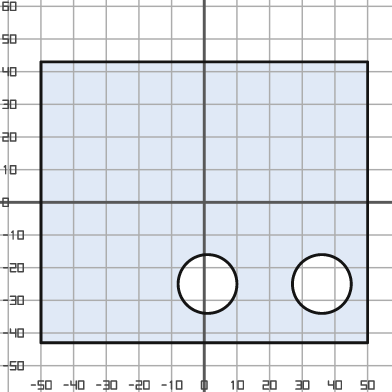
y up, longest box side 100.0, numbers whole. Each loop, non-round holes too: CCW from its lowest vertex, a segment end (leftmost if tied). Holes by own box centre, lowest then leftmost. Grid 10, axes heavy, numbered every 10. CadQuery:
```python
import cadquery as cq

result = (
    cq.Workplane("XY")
    .moveTo(-50.0, -43.0)
    .lineTo(50.0, -43.0)
    .lineTo(50.0, 43.0)
    .lineTo(-50.0, 43.0)
    .close()
    .moveTo(1.0, -25.0)
    .circle(9.0)
    .moveTo(36.0, -25.0)
    .circle(9.0)
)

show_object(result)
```